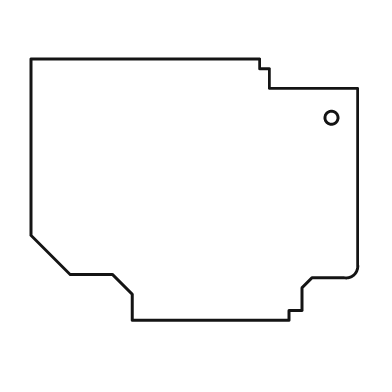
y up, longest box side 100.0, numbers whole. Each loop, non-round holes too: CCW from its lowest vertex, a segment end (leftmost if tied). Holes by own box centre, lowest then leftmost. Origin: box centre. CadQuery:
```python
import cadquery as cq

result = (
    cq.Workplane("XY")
    .moveTo(-19.0, -40.0)
    .lineTo(29.0, -40.0)
    .lineTo(29.0, -37.0)
    .lineTo(33.0, -37.0)
    .lineTo(33.0, -30.0)
    .lineTo(36.0, -27.0)
    .lineTo(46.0, -27.0)
    .threePointArc((49.0, -26.0), (50.0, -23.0))
    .lineTo(50.0, 31.0)
    .lineTo(23.0, 31.0)
    .lineTo(23.0, 37.0)
    .lineTo(20.0, 37.0)
    .lineTo(20.0, 40.0)
    .lineTo(-50.0, 40.0)
    .lineTo(-50.0, -14.0)
    .lineTo(-38.0, -26.0)
    .lineTo(-25.0, -26.0)
    .lineTo(-19.0, -32.0)
    .close()
    .moveTo(42.0, 22.0)
    .circle(2.0)
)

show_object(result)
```